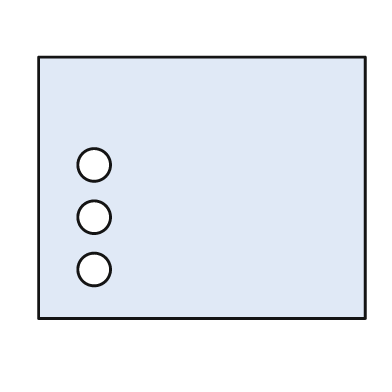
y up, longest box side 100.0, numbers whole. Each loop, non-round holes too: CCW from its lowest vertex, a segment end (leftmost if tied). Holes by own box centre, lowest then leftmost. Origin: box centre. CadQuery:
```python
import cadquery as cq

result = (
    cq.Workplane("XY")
    .moveTo(-50.0, -40.0)
    .lineTo(50.0, -40.0)
    .lineTo(50.0, 40.0)
    .lineTo(-50.0, 40.0)
    .close()
    .moveTo(-33.0, -25.0)
    .circle(5.0)
    .moveTo(-33.0, -9.0)
    .circle(5.0)
    .moveTo(-33.0, 7.0)
    .circle(5.0)
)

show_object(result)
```